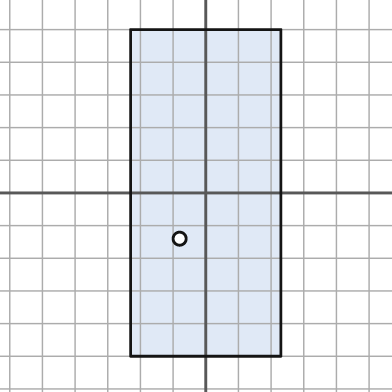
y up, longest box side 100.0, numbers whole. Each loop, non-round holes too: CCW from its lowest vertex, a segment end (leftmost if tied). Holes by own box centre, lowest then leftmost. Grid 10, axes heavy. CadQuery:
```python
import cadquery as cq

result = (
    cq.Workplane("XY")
    .moveTo(-23.0, -50.0)
    .lineTo(23.0, -50.0)
    .lineTo(23.0, 50.0)
    .lineTo(-23.0, 50.0)
    .close()
    .moveTo(-8.0, -14.0)
    .circle(2.0)
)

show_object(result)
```